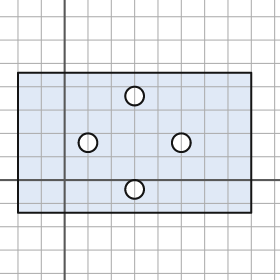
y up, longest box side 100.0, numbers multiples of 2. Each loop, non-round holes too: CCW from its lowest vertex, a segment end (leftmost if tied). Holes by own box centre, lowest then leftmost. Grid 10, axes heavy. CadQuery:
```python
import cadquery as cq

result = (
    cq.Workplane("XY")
    .moveTo(-20.0, -14.0)
    .lineTo(80.0, -14.0)
    .lineTo(80.0, 46.0)
    .lineTo(-20.0, 46.0)
    .close()
    .moveTo(30.0, -4.0)
    .circle(4.0)
    .moveTo(10.0, 16.0)
    .circle(4.0)
    .moveTo(50.0, 16.0)
    .circle(4.0)
    .moveTo(30.0, 36.0)
    .circle(4.0)
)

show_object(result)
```